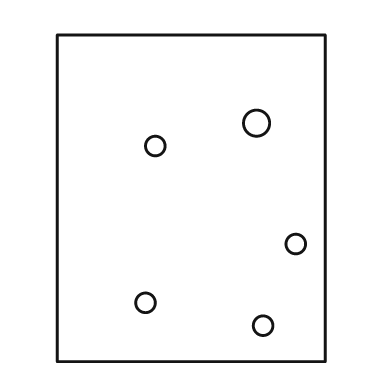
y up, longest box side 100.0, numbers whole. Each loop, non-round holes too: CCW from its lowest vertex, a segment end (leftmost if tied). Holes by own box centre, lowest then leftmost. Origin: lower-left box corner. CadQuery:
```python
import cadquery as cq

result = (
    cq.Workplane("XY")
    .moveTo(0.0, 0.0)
    .lineTo(82.0, 0.0)
    .lineTo(82.0, 100.0)
    .lineTo(0.0, 100.0)
    .close()
    .moveTo(63.0, 11.0)
    .circle(3.0)
    .moveTo(27.0, 18.0)
    .circle(3.0)
    .moveTo(73.0, 36.0)
    .circle(3.0)
    .moveTo(30.0, 66.0)
    .circle(3.0)
    .moveTo(61.0, 73.0)
    .circle(4.0)
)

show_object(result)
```